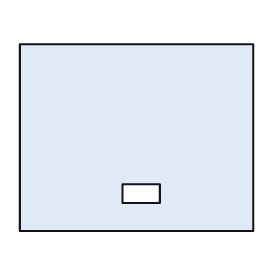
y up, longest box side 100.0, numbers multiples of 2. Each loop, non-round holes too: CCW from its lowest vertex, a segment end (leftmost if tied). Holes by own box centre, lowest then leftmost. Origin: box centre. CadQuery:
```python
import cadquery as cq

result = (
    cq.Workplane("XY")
    .moveTo(-50.0, -40.0)
    .lineTo(50.0, -40.0)
    .lineTo(50.0, 40.0)
    .lineTo(-50.0, 40.0)
    .close()
    .moveTo(-6.0, -28.0)
    .lineTo(10.0, -28.0)
    .lineTo(10.0, -20.0)
    .lineTo(-6.0, -20.0)
    .close()
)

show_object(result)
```